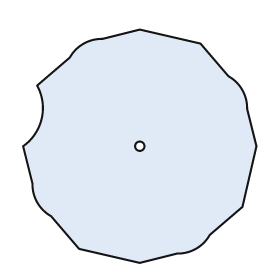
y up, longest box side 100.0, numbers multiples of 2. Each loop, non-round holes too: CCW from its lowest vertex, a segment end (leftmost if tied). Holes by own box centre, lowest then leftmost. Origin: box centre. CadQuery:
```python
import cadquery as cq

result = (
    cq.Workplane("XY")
    .moveTo(0.0, -50.0)
    .lineTo(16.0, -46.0)
    .threePointArc((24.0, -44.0), (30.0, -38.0))
    .lineTo(44.0, -26.0)
    .lineTo(50.0, 0.0)
    .lineTo(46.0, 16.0)
    .threePointArc((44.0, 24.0), (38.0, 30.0))
    .lineTo(26.0, 44.0)
    .lineTo(0.0, 50.0)
    .lineTo(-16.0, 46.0)
    .threePointArc((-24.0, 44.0), (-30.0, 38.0))
    .lineTo(-44.0, 26.0)
    .threePointArc((-42.0, 12.0), (-50.0, 0.0))
    .lineTo(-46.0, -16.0)
    .threePointArc((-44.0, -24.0), (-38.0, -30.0))
    .lineTo(-26.0, -44.0)
    .close()
    .moveTo(0.0, 0.0)
    .circle(2.0)
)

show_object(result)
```